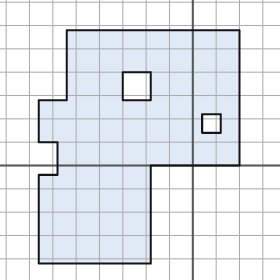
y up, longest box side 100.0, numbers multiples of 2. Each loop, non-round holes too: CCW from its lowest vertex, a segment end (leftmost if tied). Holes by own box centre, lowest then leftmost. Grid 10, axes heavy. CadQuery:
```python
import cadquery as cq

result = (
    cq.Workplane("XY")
    .moveTo(-66.0, -42.0)
    .lineTo(-18.0, -42.0)
    .lineTo(-18.0, 0.0)
    .lineTo(20.0, 0.0)
    .lineTo(20.0, 58.0)
    .lineTo(-54.0, 58.0)
    .lineTo(-54.0, 28.0)
    .lineTo(-66.0, 28.0)
    .lineTo(-66.0, 10.0)
    .lineTo(-58.0, 10.0)
    .lineTo(-58.0, -4.0)
    .lineTo(-66.0, -4.0)
    .close()
    .moveTo(4.0, 14.0)
    .lineTo(12.0, 14.0)
    .lineTo(12.0, 22.0)
    .lineTo(4.0, 22.0)
    .close()
    .moveTo(-30.0, 28.0)
    .lineTo(-18.0, 28.0)
    .lineTo(-18.0, 40.0)
    .lineTo(-30.0, 40.0)
    .close()
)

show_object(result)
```